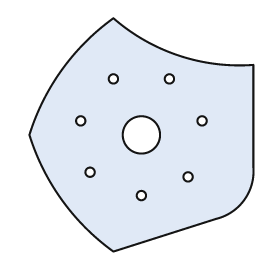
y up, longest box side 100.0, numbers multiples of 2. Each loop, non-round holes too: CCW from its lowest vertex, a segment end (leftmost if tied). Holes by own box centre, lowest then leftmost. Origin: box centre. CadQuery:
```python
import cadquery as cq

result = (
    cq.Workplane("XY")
    .moveTo(-12.0, -50.0)
    .lineTo(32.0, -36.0)
    .threePointArc((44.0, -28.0), (48.0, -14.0))
    .lineTo(48.0, 30.0)
    .threePointArc((16.0, 34.0), (-12.0, 50.0))
    .threePointArc((-34.0, 28.0), (-48.0, 0.0))
    .threePointArc((-34.0, -28.0), (-12.0, -50.0))
    .close()
    .moveTo(0.0, -26.0)
    .circle(2.0)
    .moveTo(20.0, -18.0)
    .circle(2.0)
    .moveTo(-22.0, -16.0)
    .circle(2.0)
    .moveTo(0.0, 0.0)
    .circle(8.0)
    .moveTo(-26.0, 6.0)
    .circle(2.0)
    .moveTo(26.0, 6.0)
    .circle(2.0)
    .moveTo(-12.0, 24.0)
    .circle(2.0)
    .moveTo(12.0, 24.0)
    .circle(2.0)
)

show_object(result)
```